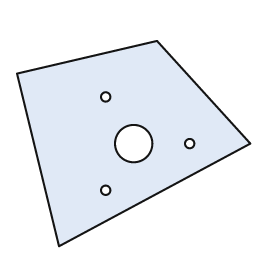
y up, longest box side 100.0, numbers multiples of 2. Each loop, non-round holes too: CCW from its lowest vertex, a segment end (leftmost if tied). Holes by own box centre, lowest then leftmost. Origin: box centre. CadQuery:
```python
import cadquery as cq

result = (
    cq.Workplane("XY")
    .moveTo(-32.0, -44.0)
    .lineTo(50.0, 0.0)
    .lineTo(10.0, 44.0)
    .lineTo(-50.0, 30.0)
    .close()
    .moveTo(-12.0, -20.0)
    .circle(2.0)
    .moveTo(0.0, 0.0)
    .circle(8.0)
    .moveTo(24.0, 0.0)
    .circle(2.0)
    .moveTo(-12.0, 20.0)
    .circle(2.0)
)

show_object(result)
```